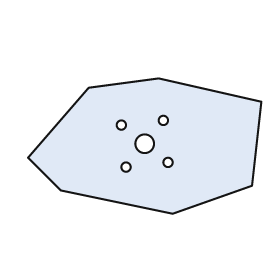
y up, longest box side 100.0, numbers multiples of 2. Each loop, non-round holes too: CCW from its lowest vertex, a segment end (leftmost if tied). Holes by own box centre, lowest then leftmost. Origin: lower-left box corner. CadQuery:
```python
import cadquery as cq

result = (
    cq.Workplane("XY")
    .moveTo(62.0, 0.0)
    .lineTo(96.0, 12.0)
    .lineTo(100.0, 48.0)
    .lineTo(56.0, 58.0)
    .lineTo(26.0, 54.0)
    .lineTo(0.0, 24.0)
    .lineTo(14.0, 10.0)
    .close()
    .moveTo(42.0, 20.0)
    .circle(2.0)
    .moveTo(60.0, 22.0)
    .circle(2.0)
    .moveTo(50.0, 30.0)
    .circle(4.0)
    .moveTo(40.0, 38.0)
    .circle(2.0)
    .moveTo(58.0, 40.0)
    .circle(2.0)
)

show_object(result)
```